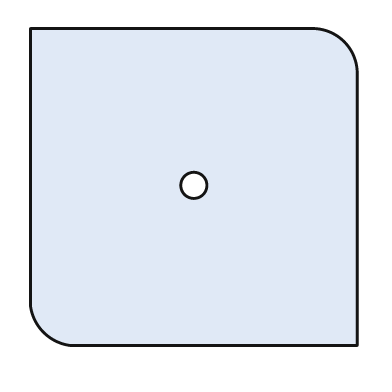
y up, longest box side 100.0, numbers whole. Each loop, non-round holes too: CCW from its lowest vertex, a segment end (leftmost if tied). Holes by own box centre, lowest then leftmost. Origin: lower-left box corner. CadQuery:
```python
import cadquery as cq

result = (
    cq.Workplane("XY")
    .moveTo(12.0, 0.0)
    .lineTo(100.0, 0.0)
    .lineTo(100.0, 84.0)
    .threePointArc((96.0, 93.0), (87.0, 97.0))
    .lineTo(0.0, 97.0)
    .lineTo(0.0, 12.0)
    .threePointArc((4.0, 4.0), (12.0, 0.0))
    .close()
    .moveTo(50.0, 49.0)
    .circle(4.0)
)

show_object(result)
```